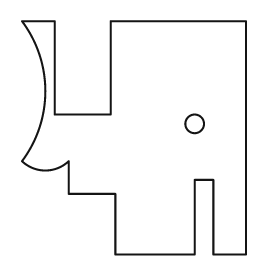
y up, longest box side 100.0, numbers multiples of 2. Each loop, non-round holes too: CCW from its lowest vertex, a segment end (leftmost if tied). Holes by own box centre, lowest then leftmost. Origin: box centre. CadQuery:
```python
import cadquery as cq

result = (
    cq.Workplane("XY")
    .moveTo(-8.0, -50.0)
    .lineTo(26.0, -50.0)
    .lineTo(26.0, -18.0)
    .lineTo(34.0, -18.0)
    .lineTo(34.0, -50.0)
    .lineTo(48.0, -50.0)
    .lineTo(48.0, 50.0)
    .lineTo(-10.0, 50.0)
    .lineTo(-10.0, 10.0)
    .lineTo(-34.0, 10.0)
    .lineTo(-34.0, 50.0)
    .lineTo(-48.0, 50.0)
    .threePointArc((-38.0, 20.0), (-48.0, -10.0))
    .threePointArc((-38.0, -14.0), (-28.0, -10.0))
    .lineTo(-28.0, -24.0)
    .lineTo(-8.0, -24.0)
    .close()
    .moveTo(26.0, 6.0)
    .circle(4.0)
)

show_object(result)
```